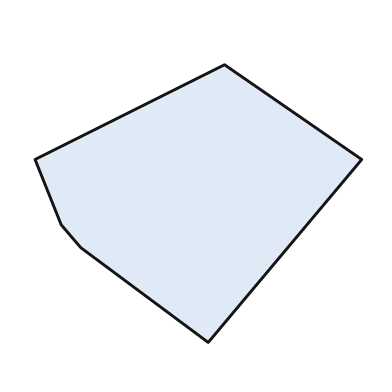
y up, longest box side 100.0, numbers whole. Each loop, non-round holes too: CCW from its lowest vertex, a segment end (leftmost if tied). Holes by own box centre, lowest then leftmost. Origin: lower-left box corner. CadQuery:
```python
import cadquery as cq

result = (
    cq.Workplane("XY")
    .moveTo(53.0, 0.0)
    .lineTo(100.0, 56.0)
    .lineTo(58.0, 85.0)
    .lineTo(0.0, 56.0)
    .lineTo(8.0, 36.0)
    .lineTo(14.0, 29.0)
    .close()
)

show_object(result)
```